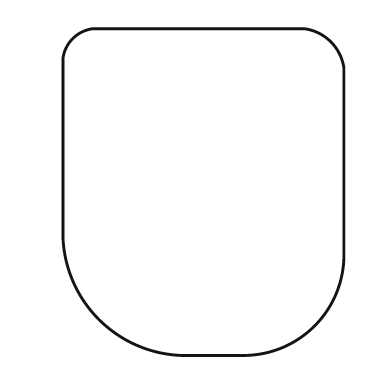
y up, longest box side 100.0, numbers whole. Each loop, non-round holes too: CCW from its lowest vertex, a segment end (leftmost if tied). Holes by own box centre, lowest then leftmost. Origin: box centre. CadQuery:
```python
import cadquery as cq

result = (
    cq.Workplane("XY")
    .moveTo(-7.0, -50.0)
    .lineTo(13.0, -50.0)
    .threePointArc((34.0, -41.0), (43.0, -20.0))
    .lineTo(43.0, 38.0)
    .threePointArc((39.0, 46.0), (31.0, 50.0))
    .lineTo(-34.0, 50.0)
    .threePointArc((-40.0, 47.0), (-43.0, 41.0))
    .lineTo(-43.0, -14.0)
    .threePointArc((-32.0, -39.0), (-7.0, -50.0))
    .close()
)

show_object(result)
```